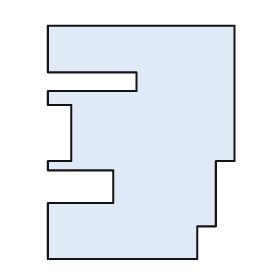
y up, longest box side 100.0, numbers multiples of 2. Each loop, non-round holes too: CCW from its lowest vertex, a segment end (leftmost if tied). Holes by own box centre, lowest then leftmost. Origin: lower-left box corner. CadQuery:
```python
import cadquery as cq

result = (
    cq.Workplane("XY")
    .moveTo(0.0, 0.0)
    .lineTo(64.0, 0.0)
    .lineTo(64.0, 14.0)
    .lineTo(72.0, 14.0)
    .lineTo(72.0, 42.0)
    .lineTo(80.0, 42.0)
    .lineTo(80.0, 100.0)
    .lineTo(0.0, 100.0)
    .lineTo(0.0, 80.0)
    .lineTo(38.0, 80.0)
    .lineTo(38.0, 72.0)
    .lineTo(0.0, 72.0)
    .lineTo(0.0, 66.0)
    .lineTo(10.0, 66.0)
    .lineTo(10.0, 42.0)
    .lineTo(0.0, 42.0)
    .lineTo(0.0, 38.0)
    .lineTo(28.0, 38.0)
    .lineTo(28.0, 24.0)
    .lineTo(0.0, 24.0)
    .close()
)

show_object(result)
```